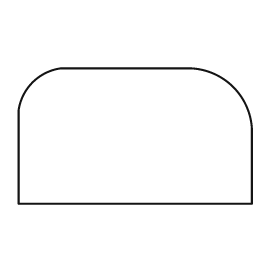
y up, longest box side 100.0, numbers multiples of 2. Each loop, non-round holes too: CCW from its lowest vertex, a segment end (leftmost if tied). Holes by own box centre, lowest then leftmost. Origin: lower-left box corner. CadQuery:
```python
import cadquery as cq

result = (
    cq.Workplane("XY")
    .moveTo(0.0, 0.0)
    .lineTo(100.0, 0.0)
    .lineTo(100.0, 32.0)
    .threePointArc((92.0, 50.0), (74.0, 58.0))
    .lineTo(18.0, 58.0)
    .threePointArc((6.0, 52.0), (0.0, 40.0))
    .close()
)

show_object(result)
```